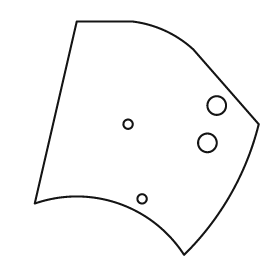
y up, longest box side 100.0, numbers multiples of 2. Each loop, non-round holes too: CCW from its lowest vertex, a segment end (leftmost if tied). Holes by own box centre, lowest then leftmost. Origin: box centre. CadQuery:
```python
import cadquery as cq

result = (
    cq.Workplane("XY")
    .moveTo(16.0, -50.0)
    .threePointArc((36.0, -24.0), (48.0, 6.0))
    .lineTo(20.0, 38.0)
    .threePointArc((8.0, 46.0), (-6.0, 50.0))
    .lineTo(-30.0, 50.0)
    .lineTo(-48.0, -28.0)
    .threePointArc((-12.0, -28.0), (16.0, -50.0))
    .close()
    .moveTo(-2.0, -26.0)
    .circle(2.0)
    .moveTo(26.0, -2.0)
    .circle(4.0)
    .moveTo(-8.0, 6.0)
    .circle(2.0)
    .moveTo(30.0, 14.0)
    .circle(4.0)
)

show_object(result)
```